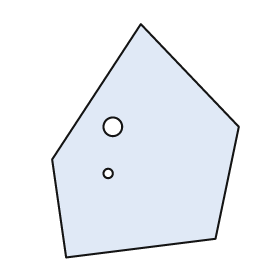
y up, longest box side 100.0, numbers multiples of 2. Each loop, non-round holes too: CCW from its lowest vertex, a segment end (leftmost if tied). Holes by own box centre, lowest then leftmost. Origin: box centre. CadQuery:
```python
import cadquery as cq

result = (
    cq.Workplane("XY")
    .moveTo(-34.0, -50.0)
    .lineTo(30.0, -42.0)
    .lineTo(40.0, 6.0)
    .lineTo(-2.0, 50.0)
    .lineTo(-40.0, -8.0)
    .close()
    .moveTo(-16.0, -14.0)
    .circle(2.0)
    .moveTo(-14.0, 6.0)
    .circle(4.0)
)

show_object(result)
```